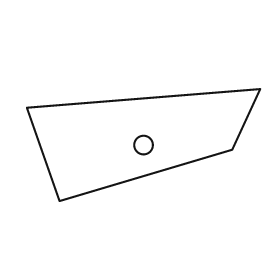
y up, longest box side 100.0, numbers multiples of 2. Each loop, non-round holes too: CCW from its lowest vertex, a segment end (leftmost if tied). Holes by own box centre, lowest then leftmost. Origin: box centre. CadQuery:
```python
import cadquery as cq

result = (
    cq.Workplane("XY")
    .moveTo(-36.0, -24.0)
    .lineTo(38.0, -2.0)
    .lineTo(50.0, 24.0)
    .lineTo(-50.0, 16.0)
    .close()
    .moveTo(0.0, 0.0)
    .circle(4.0)
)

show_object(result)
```